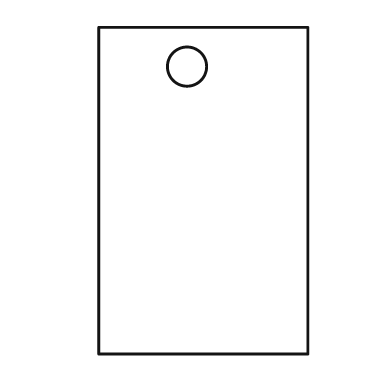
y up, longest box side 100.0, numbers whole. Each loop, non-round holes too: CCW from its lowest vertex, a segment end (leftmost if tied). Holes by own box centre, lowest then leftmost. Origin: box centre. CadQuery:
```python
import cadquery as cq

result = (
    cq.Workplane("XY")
    .moveTo(-32.0, -50.0)
    .lineTo(32.0, -50.0)
    .lineTo(32.0, 50.0)
    .lineTo(-32.0, 50.0)
    .close()
    .moveTo(-5.0, 38.0)
    .circle(6.0)
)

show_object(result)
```